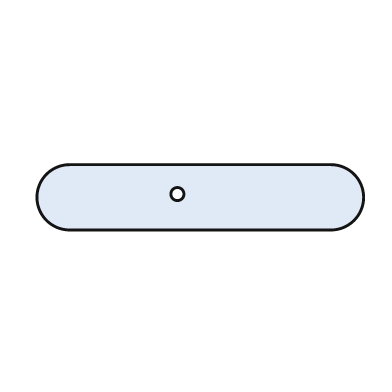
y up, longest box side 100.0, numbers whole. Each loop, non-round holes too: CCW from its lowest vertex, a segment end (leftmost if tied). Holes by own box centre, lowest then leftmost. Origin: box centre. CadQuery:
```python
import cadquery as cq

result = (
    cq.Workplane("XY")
    .moveTo(-40.0, -10.0)
    .lineTo(40.0, -10.0)
    .threePointArc((50.0, 0.0), (40.0, 10.0))
    .lineTo(-40.0, 10.0)
    .threePointArc((-50.0, 0.0), (-40.0, -10.0))
    .close()
    .moveTo(-7.0, 1.0)
    .circle(2.0)
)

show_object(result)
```